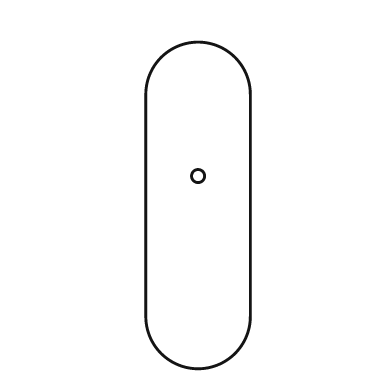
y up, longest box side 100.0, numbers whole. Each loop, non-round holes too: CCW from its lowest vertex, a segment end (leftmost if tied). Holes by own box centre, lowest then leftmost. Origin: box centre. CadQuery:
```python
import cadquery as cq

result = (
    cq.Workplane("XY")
    .moveTo(-16.0, -34.0)
    .threePointArc((0.0, -50.0), (16.0, -34.0))
    .lineTo(16.0, 34.0)
    .threePointArc((0.0, 50.0), (-16.0, 34.0))
    .close()
    .moveTo(0.0, 9.0)
    .circle(2.0)
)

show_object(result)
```